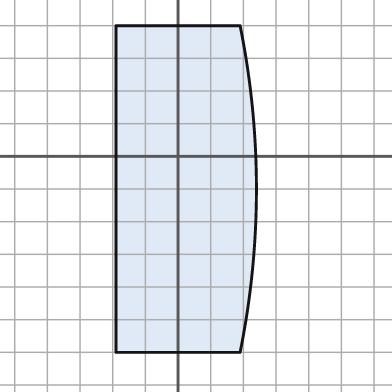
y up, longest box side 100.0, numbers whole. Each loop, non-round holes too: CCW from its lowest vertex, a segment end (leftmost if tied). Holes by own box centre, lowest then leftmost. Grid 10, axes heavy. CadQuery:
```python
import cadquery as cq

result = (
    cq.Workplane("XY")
    .moveTo(-19.0, -60.0)
    .lineTo(19.0, -60.0)
    .threePointArc((24.0, -10.0), (19.0, 40.0))
    .lineTo(-19.0, 40.0)
    .close()
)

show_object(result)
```